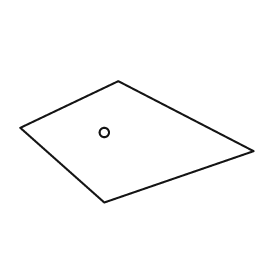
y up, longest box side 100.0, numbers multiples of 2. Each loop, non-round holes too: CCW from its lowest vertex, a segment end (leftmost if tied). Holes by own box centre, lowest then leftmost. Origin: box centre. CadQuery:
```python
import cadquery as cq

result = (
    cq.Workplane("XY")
    .moveTo(-14.0, -26.0)
    .lineTo(50.0, -4.0)
    .lineTo(-8.0, 26.0)
    .lineTo(-50.0, 6.0)
    .close()
    .moveTo(-14.0, 4.0)
    .circle(2.0)
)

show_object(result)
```